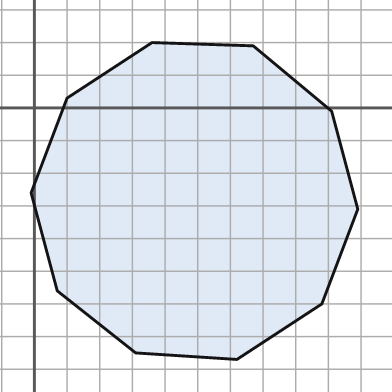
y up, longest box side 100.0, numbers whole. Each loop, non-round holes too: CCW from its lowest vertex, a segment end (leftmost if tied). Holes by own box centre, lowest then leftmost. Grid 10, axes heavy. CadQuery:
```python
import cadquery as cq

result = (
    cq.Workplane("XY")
    .moveTo(62.0, -77.0)
    .lineTo(88.0, -60.0)
    .lineTo(99.0, -31.0)
    .lineTo(91.0, -1.0)
    .lineTo(67.0, 19.0)
    .lineTo(36.0, 20.0)
    .lineTo(10.0, 3.0)
    .lineTo(-1.0, -26.0)
    .lineTo(7.0, -56.0)
    .lineTo(31.0, -75.0)
    .close()
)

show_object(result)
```